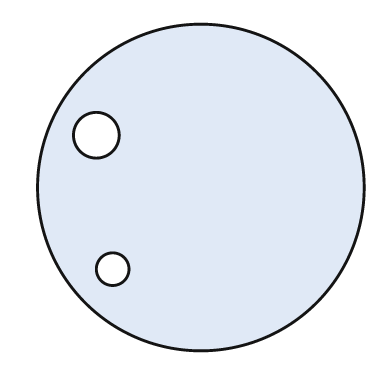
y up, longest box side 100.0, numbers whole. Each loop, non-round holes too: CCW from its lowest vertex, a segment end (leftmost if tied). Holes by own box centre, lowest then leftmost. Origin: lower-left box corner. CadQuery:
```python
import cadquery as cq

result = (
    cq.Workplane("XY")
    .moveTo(50.0, 50.0)
    .circle(50.0)
    .moveTo(23.0, 25.0)
    .circle(5.0)
    .moveTo(18.0, 66.0)
    .circle(7.0)
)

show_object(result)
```